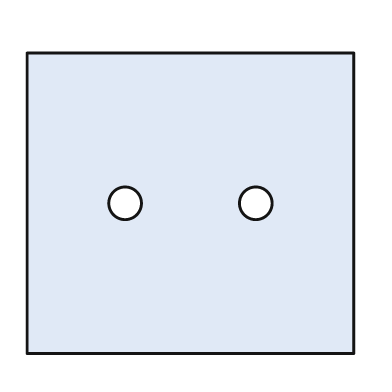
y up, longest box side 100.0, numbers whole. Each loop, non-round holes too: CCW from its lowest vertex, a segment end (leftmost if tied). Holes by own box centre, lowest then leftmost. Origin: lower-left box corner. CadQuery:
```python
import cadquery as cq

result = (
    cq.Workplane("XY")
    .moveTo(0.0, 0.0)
    .lineTo(100.0, 0.0)
    .lineTo(100.0, 92.0)
    .lineTo(0.0, 92.0)
    .close()
    .moveTo(30.0, 46.0)
    .circle(5.0)
    .moveTo(70.0, 46.0)
    .circle(5.0)
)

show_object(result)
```